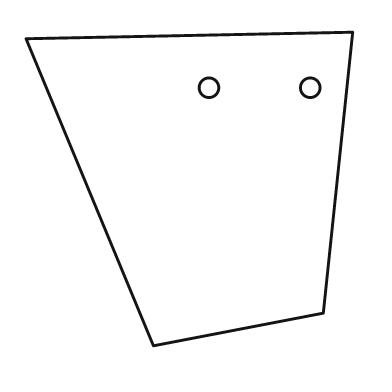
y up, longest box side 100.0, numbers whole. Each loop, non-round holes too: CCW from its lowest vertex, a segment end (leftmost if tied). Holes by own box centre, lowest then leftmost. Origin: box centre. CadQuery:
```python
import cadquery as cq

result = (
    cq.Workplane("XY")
    .moveTo(-11.0, -48.0)
    .lineTo(41.0, -38.0)
    .lineTo(50.0, 48.0)
    .lineTo(-50.0, 46.0)
    .close()
    .moveTo(6.0, 31.0)
    .circle(3.0)
    .moveTo(37.0, 31.0)
    .circle(3.0)
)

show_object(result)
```